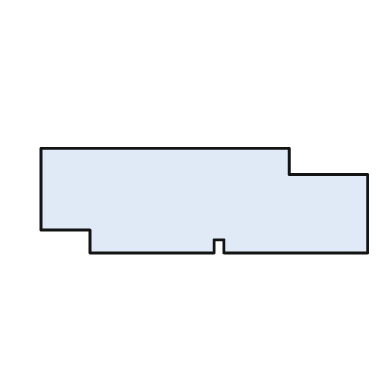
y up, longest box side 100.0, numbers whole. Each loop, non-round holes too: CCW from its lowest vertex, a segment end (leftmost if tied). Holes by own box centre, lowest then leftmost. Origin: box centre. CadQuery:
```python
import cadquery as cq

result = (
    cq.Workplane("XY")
    .moveTo(-35.0, -16.0)
    .lineTo(3.0, -16.0)
    .lineTo(3.0, -12.0)
    .lineTo(6.0, -12.0)
    .lineTo(6.0, -16.0)
    .lineTo(50.0, -16.0)
    .lineTo(50.0, 8.0)
    .lineTo(26.0, 8.0)
    .lineTo(26.0, 16.0)
    .lineTo(-50.0, 16.0)
    .lineTo(-50.0, -9.0)
    .lineTo(-35.0, -9.0)
    .close()
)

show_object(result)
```